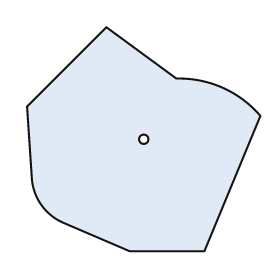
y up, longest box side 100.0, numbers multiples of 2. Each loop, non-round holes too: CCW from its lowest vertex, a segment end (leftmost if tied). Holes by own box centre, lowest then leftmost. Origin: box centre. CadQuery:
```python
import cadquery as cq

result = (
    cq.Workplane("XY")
    .moveTo(-6.0, -48.0)
    .lineTo(26.0, -48.0)
    .lineTo(50.0, 10.0)
    .threePointArc((34.0, 22.0), (14.0, 26.0))
    .lineTo(-16.0, 48.0)
    .lineTo(-50.0, 14.0)
    .lineTo(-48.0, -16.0)
    .threePointArc((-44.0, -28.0), (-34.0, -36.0))
    .close()
    .moveTo(0.0, 0.0)
    .circle(2.0)
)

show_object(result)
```